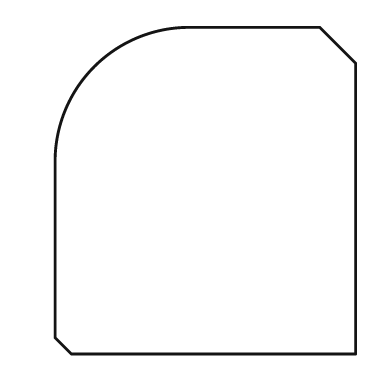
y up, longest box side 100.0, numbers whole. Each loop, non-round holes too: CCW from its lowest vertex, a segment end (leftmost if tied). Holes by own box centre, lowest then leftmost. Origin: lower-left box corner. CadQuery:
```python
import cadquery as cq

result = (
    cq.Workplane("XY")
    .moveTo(5.0, 0.0)
    .lineTo(92.0, 0.0)
    .lineTo(92.0, 89.0)
    .lineTo(81.0, 100.0)
    .lineTo(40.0, 100.0)
    .threePointArc((12.0, 88.0), (0.0, 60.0))
    .lineTo(0.0, 5.0)
    .close()
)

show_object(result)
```